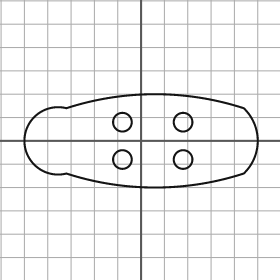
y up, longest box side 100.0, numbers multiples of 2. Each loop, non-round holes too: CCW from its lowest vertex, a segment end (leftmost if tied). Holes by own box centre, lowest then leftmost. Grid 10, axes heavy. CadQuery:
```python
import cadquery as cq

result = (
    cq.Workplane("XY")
    .moveTo(-32.0, -14.0)
    .threePointArc((6.0, -20.0), (44.0, -14.0))
    .threePointArc((50.0, 0.0), (44.0, 14.0))
    .threePointArc((6.0, 20.0), (-32.0, 14.0))
    .threePointArc((-50.0, 0.0), (-32.0, -14.0))
    .close()
    .moveTo(-8.0, -8.0)
    .circle(4.0)
    .moveTo(18.0, -8.0)
    .circle(4.0)
    .moveTo(-8.0, 8.0)
    .circle(4.0)
    .moveTo(18.0, 8.0)
    .circle(4.0)
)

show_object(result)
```